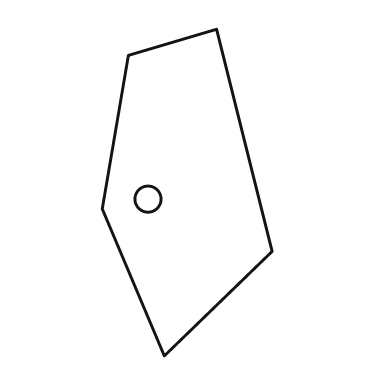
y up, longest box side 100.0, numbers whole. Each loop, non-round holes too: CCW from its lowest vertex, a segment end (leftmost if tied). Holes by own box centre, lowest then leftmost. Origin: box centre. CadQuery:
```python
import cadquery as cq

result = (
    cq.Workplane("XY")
    .moveTo(-7.0, -50.0)
    .lineTo(26.0, -18.0)
    .lineTo(9.0, 50.0)
    .lineTo(-18.0, 42.0)
    .lineTo(-26.0, -5.0)
    .close()
    .moveTo(-12.0, -2.0)
    .circle(4.0)
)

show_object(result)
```